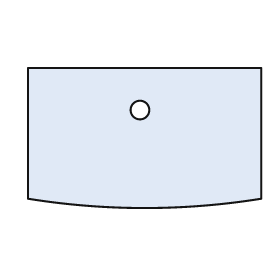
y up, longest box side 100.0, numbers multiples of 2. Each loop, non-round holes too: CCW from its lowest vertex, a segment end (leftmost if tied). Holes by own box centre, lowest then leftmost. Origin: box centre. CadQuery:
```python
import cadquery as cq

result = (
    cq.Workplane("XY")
    .moveTo(-50.0, -26.0)
    .threePointArc((0.0, -30.0), (50.0, -26.0))
    .lineTo(50.0, 30.0)
    .lineTo(-50.0, 30.0)
    .close()
    .moveTo(-2.0, 12.0)
    .circle(4.0)
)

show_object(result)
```